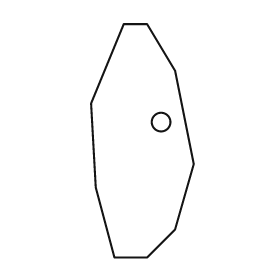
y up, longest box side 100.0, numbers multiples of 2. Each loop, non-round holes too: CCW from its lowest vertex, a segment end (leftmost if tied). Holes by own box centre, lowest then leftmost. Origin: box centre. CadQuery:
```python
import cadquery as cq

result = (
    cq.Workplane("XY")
    .moveTo(-12.0, -50.0)
    .lineTo(2.0, -50.0)
    .lineTo(14.0, -38.0)
    .lineTo(22.0, -10.0)
    .lineTo(14.0, 30.0)
    .lineTo(2.0, 50.0)
    .lineTo(-8.0, 50.0)
    .lineTo(-22.0, 16.0)
    .lineTo(-20.0, -20.0)
    .close()
    .moveTo(8.0, 8.0)
    .circle(4.0)
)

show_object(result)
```